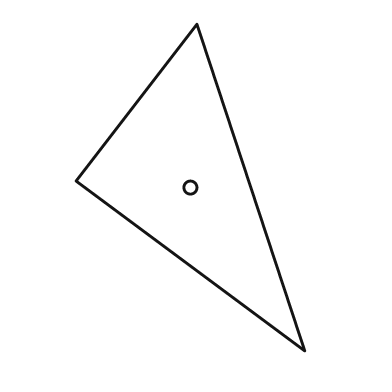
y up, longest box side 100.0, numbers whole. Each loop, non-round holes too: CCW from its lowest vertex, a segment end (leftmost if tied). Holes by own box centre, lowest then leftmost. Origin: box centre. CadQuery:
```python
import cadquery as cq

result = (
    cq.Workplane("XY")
    .moveTo(35.0, -50.0)
    .lineTo(2.0, 50.0)
    .lineTo(-35.0, 2.0)
    .close()
    .moveTo(0.0, 0.0)
    .circle(2.0)
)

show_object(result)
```